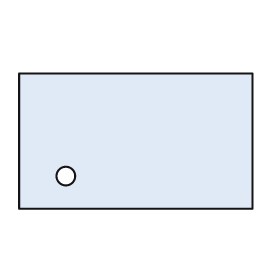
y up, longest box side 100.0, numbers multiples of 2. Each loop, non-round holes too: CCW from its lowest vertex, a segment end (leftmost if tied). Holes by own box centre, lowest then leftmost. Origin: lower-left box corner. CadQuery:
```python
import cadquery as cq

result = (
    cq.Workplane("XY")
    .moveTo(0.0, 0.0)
    .lineTo(100.0, 0.0)
    .lineTo(100.0, 58.0)
    .lineTo(0.0, 58.0)
    .close()
    .moveTo(20.0, 14.0)
    .circle(4.0)
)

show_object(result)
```